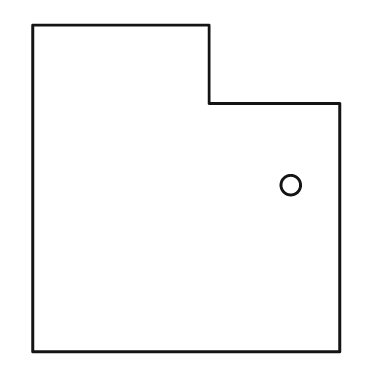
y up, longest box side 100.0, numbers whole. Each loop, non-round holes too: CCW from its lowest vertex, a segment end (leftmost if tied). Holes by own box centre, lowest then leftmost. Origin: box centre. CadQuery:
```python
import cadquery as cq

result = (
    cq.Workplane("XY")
    .moveTo(-47.0, -50.0)
    .lineTo(47.0, -50.0)
    .lineTo(47.0, 26.0)
    .lineTo(7.0, 26.0)
    .lineTo(7.0, 50.0)
    .lineTo(-47.0, 50.0)
    .close()
    .moveTo(32.0, 1.0)
    .circle(3.0)
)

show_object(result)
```